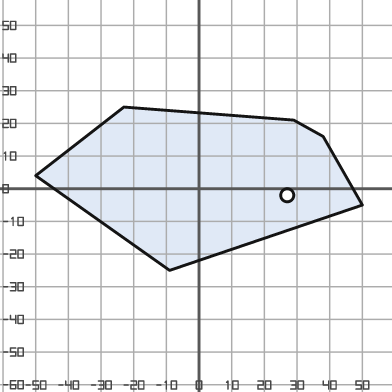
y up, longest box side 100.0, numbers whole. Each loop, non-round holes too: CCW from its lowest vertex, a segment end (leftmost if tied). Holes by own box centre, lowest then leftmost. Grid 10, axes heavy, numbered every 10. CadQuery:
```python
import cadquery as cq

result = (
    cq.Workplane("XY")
    .moveTo(-9.0, -25.0)
    .lineTo(50.0, -5.0)
    .lineTo(38.0, 16.0)
    .lineTo(29.0, 21.0)
    .lineTo(-23.0, 25.0)
    .lineTo(-50.0, 4.0)
    .close()
    .moveTo(27.0, -2.0)
    .circle(2.0)
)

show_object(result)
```